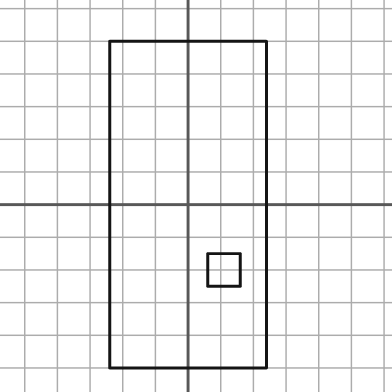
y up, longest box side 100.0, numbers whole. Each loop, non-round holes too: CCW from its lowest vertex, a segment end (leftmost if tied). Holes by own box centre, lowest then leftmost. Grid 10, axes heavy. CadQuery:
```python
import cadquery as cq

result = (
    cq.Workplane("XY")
    .moveTo(-24.0, -50.0)
    .lineTo(24.0, -50.0)
    .lineTo(24.0, 50.0)
    .lineTo(-24.0, 50.0)
    .close()
    .moveTo(6.0, -25.0)
    .lineTo(16.0, -25.0)
    .lineTo(16.0, -15.0)
    .lineTo(6.0, -15.0)
    .close()
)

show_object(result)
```